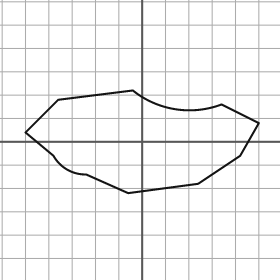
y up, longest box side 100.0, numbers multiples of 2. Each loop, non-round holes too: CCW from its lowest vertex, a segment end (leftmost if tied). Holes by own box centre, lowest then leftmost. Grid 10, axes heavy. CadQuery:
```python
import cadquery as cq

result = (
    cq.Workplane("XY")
    .moveTo(-6.0, -22.0)
    .lineTo(24.0, -18.0)
    .lineTo(42.0, -6.0)
    .lineTo(50.0, 8.0)
    .lineTo(34.0, 16.0)
    .threePointArc((14.0, 14.0), (-4.0, 22.0))
    .lineTo(-36.0, 18.0)
    .lineTo(-50.0, 4.0)
    .lineTo(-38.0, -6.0)
    .threePointArc((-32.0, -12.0), (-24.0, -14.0))
    .close()
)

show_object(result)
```